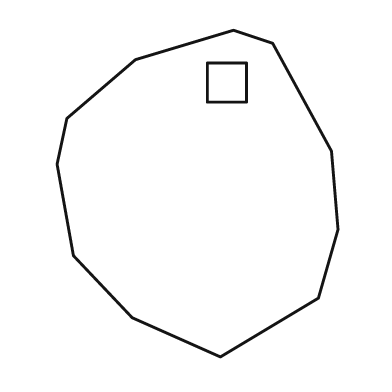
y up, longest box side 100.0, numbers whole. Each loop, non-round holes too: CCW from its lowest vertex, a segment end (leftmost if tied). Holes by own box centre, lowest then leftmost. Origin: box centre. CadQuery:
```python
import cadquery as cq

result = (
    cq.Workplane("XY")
    .moveTo(7.0, -50.0)
    .lineTo(37.0, -32.0)
    .lineTo(43.0, -11.0)
    .lineTo(41.0, 13.0)
    .lineTo(23.0, 46.0)
    .lineTo(11.0, 50.0)
    .lineTo(-19.0, 41.0)
    .lineTo(-40.0, 23.0)
    .lineTo(-43.0, 9.0)
    .lineTo(-38.0, -19.0)
    .lineTo(-20.0, -38.0)
    .close()
    .moveTo(3.0, 28.0)
    .lineTo(15.0, 28.0)
    .lineTo(15.0, 40.0)
    .lineTo(3.0, 40.0)
    .close()
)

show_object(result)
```